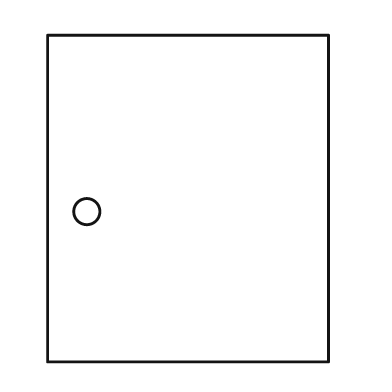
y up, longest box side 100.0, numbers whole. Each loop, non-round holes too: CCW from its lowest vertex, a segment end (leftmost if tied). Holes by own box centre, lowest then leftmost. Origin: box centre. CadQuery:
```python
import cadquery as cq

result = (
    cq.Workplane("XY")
    .moveTo(-43.0, -50.0)
    .lineTo(43.0, -50.0)
    .lineTo(43.0, 50.0)
    .lineTo(-43.0, 50.0)
    .close()
    .moveTo(-31.0, -4.0)
    .circle(4.0)
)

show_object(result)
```